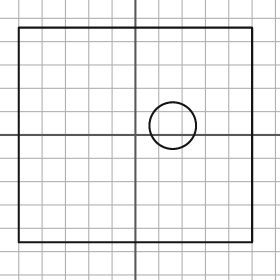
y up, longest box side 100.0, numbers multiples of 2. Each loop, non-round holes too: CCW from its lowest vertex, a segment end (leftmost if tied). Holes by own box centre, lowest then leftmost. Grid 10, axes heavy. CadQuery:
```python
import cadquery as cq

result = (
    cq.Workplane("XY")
    .moveTo(-50.0, -46.0)
    .lineTo(50.0, -46.0)
    .lineTo(50.0, 46.0)
    .lineTo(-50.0, 46.0)
    .close()
    .moveTo(16.0, 4.0)
    .circle(10.0)
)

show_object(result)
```